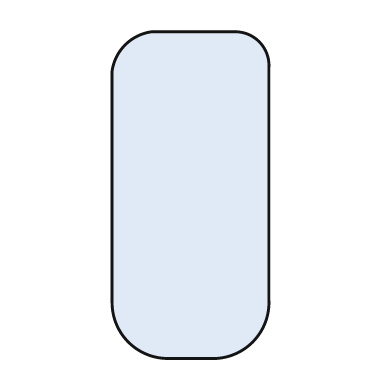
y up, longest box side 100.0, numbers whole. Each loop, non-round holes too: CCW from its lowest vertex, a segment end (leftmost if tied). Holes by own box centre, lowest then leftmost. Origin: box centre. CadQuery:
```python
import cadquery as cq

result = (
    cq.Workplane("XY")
    .moveTo(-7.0, -50.0)
    .lineTo(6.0, -50.0)
    .threePointArc((19.0, -45.0), (24.0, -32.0))
    .lineTo(24.0, 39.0)
    .threePointArc((21.0, 47.0), (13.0, 50.0))
    .lineTo(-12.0, 50.0)
    .threePointArc((-20.0, 46.0), (-24.0, 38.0))
    .lineTo(-24.0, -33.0)
    .threePointArc((-19.0, -45.0), (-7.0, -50.0))
    .close()
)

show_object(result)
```